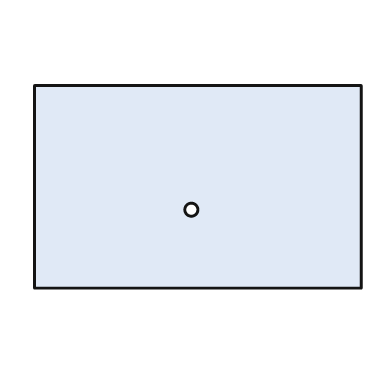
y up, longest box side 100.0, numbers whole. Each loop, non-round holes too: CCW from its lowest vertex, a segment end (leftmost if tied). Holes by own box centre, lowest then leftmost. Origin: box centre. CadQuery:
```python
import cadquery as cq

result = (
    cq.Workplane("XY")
    .moveTo(-50.0, -31.0)
    .lineTo(50.0, -31.0)
    .lineTo(50.0, 31.0)
    .lineTo(-50.0, 31.0)
    .close()
    .moveTo(-2.0, -7.0)
    .circle(2.0)
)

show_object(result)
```